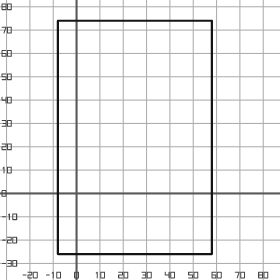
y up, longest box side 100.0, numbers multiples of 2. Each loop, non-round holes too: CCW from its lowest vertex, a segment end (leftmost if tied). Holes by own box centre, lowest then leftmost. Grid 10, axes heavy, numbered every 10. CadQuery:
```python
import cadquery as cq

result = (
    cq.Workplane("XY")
    .moveTo(-8.0, -26.0)
    .lineTo(58.0, -26.0)
    .lineTo(58.0, 74.0)
    .lineTo(-8.0, 74.0)
    .close()
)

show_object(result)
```